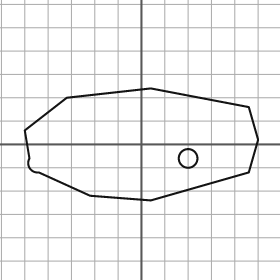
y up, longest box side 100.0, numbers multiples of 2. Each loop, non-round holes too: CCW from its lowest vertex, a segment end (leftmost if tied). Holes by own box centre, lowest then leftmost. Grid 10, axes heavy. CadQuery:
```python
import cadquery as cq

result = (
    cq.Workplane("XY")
    .moveTo(4.0, -24.0)
    .lineTo(46.0, -12.0)
    .lineTo(50.0, 2.0)
    .lineTo(46.0, 16.0)
    .lineTo(4.0, 24.0)
    .lineTo(-32.0, 20.0)
    .lineTo(-50.0, 6.0)
    .lineTo(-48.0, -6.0)
    .threePointArc((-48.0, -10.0), (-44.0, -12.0))
    .lineTo(-22.0, -22.0)
    .close()
    .moveTo(20.0, -6.0)
    .circle(4.0)
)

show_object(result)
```